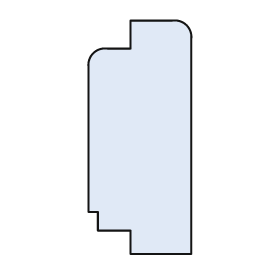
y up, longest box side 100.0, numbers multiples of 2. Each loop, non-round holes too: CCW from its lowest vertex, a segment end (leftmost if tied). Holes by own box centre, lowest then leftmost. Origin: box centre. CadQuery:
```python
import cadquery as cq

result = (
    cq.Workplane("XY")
    .moveTo(-4.0, -50.0)
    .lineTo(22.0, -50.0)
    .lineTo(22.0, 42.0)
    .threePointArc((20.0, 48.0), (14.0, 50.0))
    .lineTo(-4.0, 50.0)
    .lineTo(-4.0, 38.0)
    .lineTo(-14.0, 38.0)
    .threePointArc((-20.0, 36.0), (-22.0, 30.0))
    .lineTo(-22.0, -32.0)
    .lineTo(-18.0, -32.0)
    .lineTo(-18.0, -40.0)
    .lineTo(-4.0, -40.0)
    .close()
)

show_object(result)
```